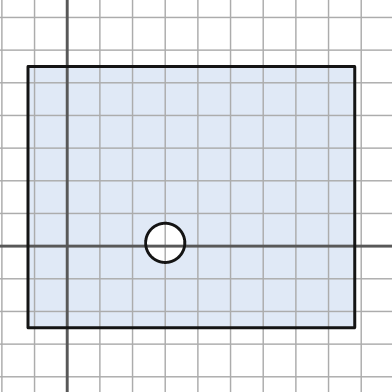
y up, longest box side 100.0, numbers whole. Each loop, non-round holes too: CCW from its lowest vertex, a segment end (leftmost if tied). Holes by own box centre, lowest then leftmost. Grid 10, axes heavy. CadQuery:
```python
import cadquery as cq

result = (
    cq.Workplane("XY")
    .moveTo(-12.0, -25.0)
    .lineTo(88.0, -25.0)
    .lineTo(88.0, 55.0)
    .lineTo(-12.0, 55.0)
    .close()
    .moveTo(30.0, 1.0)
    .circle(6.0)
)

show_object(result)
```